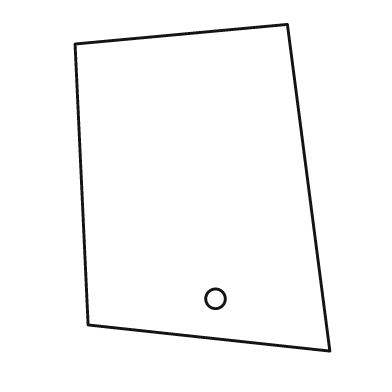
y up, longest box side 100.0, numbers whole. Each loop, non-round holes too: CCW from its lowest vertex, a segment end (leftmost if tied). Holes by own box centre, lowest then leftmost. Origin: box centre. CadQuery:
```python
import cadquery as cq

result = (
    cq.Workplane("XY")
    .moveTo(39.0, -50.0)
    .lineTo(26.0, 50.0)
    .lineTo(-39.0, 44.0)
    .lineTo(-35.0, -42.0)
    .close()
    .moveTo(4.0, -34.0)
    .circle(3.0)
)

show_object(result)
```